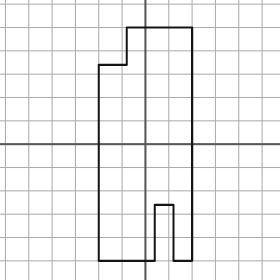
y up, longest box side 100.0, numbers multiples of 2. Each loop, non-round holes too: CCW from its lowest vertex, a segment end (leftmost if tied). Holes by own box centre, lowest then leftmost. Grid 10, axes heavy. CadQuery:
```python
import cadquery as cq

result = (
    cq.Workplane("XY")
    .moveTo(-20.0, -50.0)
    .lineTo(4.0, -50.0)
    .lineTo(4.0, -26.0)
    .lineTo(12.0, -26.0)
    .lineTo(12.0, -50.0)
    .lineTo(20.0, -50.0)
    .lineTo(20.0, 50.0)
    .lineTo(-8.0, 50.0)
    .lineTo(-8.0, 34.0)
    .lineTo(-20.0, 34.0)
    .close()
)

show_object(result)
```